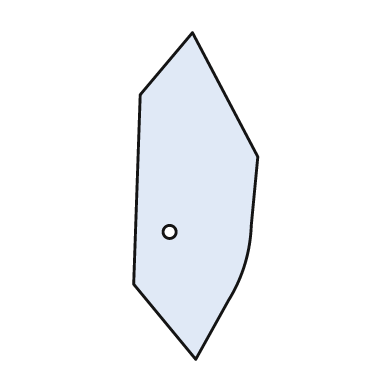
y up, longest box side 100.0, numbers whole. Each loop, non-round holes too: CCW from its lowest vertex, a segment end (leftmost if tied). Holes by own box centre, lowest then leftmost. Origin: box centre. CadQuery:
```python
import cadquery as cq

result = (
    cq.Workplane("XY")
    .moveTo(0.0, -50.0)
    .lineTo(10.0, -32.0)
    .threePointArc((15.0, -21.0), (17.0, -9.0))
    .lineTo(19.0, 12.0)
    .lineTo(-1.0, 50.0)
    .lineTo(-17.0, 31.0)
    .lineTo(-19.0, -27.0)
    .close()
    .moveTo(-8.0, -11.0)
    .circle(2.0)
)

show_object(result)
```